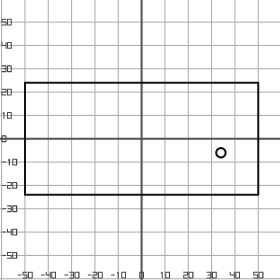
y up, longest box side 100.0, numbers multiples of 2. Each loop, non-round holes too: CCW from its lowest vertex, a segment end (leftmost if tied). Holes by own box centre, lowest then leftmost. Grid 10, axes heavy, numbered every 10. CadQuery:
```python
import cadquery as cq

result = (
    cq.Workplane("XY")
    .moveTo(-50.0, -24.0)
    .lineTo(50.0, -24.0)
    .lineTo(50.0, 24.0)
    .lineTo(-50.0, 24.0)
    .close()
    .moveTo(34.0, -6.0)
    .circle(2.0)
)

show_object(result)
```